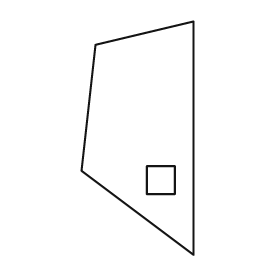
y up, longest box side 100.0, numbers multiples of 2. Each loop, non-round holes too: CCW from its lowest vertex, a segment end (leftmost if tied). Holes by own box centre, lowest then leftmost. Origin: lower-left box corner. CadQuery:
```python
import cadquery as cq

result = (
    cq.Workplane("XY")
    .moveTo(48.0, 0.0)
    .lineTo(48.0, 100.0)
    .lineTo(6.0, 90.0)
    .lineTo(0.0, 36.0)
    .close()
    .moveTo(28.0, 26.0)
    .lineTo(40.0, 26.0)
    .lineTo(40.0, 38.0)
    .lineTo(28.0, 38.0)
    .close()
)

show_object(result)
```